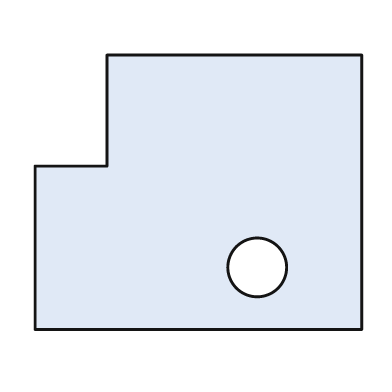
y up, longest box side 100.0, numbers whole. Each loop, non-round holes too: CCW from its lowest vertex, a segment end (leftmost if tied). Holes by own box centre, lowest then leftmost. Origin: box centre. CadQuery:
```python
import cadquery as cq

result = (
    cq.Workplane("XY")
    .moveTo(-50.0, -42.0)
    .lineTo(50.0, -42.0)
    .lineTo(50.0, 42.0)
    .lineTo(-28.0, 42.0)
    .lineTo(-28.0, 8.0)
    .lineTo(-50.0, 8.0)
    .close()
    .moveTo(18.0, -23.0)
    .circle(9.0)
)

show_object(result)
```